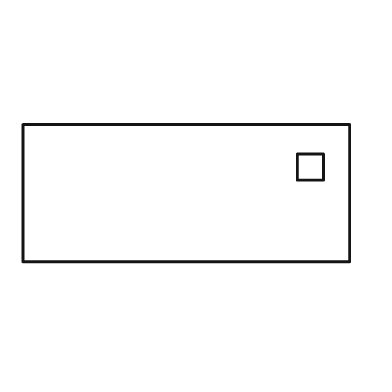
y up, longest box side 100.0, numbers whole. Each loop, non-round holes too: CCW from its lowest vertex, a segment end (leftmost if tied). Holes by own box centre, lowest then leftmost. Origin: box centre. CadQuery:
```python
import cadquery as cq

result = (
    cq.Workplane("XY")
    .moveTo(-50.0, -21.0)
    .lineTo(50.0, -21.0)
    .lineTo(50.0, 21.0)
    .lineTo(-50.0, 21.0)
    .close()
    .moveTo(34.0, 4.0)
    .lineTo(42.0, 4.0)
    .lineTo(42.0, 12.0)
    .lineTo(34.0, 12.0)
    .close()
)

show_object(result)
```